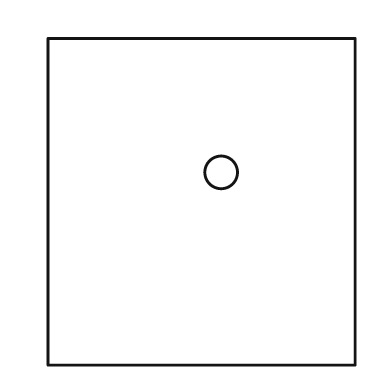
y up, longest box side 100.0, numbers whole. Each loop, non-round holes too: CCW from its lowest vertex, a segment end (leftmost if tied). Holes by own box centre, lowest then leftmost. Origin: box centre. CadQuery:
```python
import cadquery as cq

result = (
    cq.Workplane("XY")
    .moveTo(-47.0, -50.0)
    .lineTo(47.0, -50.0)
    .lineTo(47.0, 50.0)
    .lineTo(-47.0, 50.0)
    .close()
    .moveTo(6.0, 9.0)
    .circle(5.0)
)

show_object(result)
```